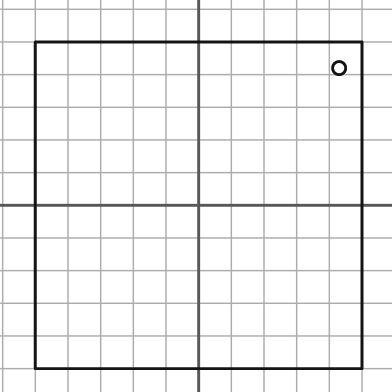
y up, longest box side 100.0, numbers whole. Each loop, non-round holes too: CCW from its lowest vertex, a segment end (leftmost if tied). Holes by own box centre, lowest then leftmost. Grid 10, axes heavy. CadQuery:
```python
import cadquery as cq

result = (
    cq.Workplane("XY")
    .moveTo(-50.0, -50.0)
    .lineTo(50.0, -50.0)
    .lineTo(50.0, 50.0)
    .lineTo(-50.0, 50.0)
    .close()
    .moveTo(43.0, 42.0)
    .circle(2.0)
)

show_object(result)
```